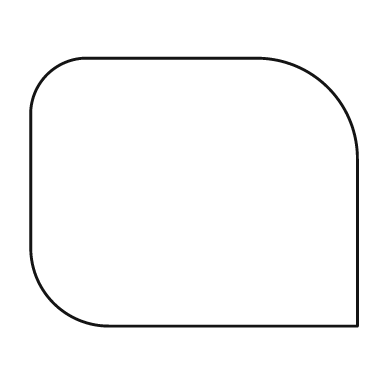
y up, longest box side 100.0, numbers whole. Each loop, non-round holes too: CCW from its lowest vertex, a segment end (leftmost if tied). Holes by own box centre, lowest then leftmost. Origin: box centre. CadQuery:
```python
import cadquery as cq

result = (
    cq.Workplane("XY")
    .moveTo(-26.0, -41.0)
    .lineTo(50.0, -41.0)
    .lineTo(50.0, 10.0)
    .threePointArc((41.0, 32.0), (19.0, 41.0))
    .lineTo(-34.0, 41.0)
    .threePointArc((-45.0, 36.0), (-50.0, 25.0))
    .lineTo(-50.0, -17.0)
    .threePointArc((-43.0, -34.0), (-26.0, -41.0))
    .close()
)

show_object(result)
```